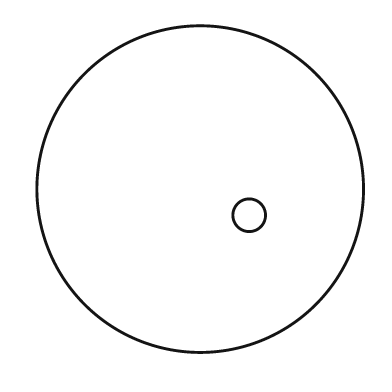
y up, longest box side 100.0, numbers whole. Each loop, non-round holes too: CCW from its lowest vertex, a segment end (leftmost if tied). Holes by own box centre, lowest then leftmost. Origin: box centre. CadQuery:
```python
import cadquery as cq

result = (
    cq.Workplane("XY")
    .moveTo(0.0, 0.0)
    .circle(50.0)
    .moveTo(15.0, -8.0)
    .circle(5.0)
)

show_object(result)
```